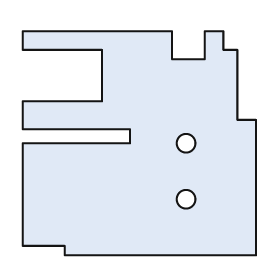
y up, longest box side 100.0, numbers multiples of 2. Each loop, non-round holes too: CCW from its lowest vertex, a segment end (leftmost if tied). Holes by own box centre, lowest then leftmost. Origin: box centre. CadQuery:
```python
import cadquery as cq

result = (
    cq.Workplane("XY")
    .moveTo(-32.0, -48.0)
    .lineTo(50.0, -48.0)
    .lineTo(50.0, 10.0)
    .lineTo(42.0, 10.0)
    .lineTo(42.0, 40.0)
    .lineTo(36.0, 40.0)
    .lineTo(36.0, 48.0)
    .lineTo(28.0, 48.0)
    .lineTo(28.0, 36.0)
    .lineTo(14.0, 36.0)
    .lineTo(14.0, 48.0)
    .lineTo(-50.0, 48.0)
    .lineTo(-50.0, 40.0)
    .lineTo(-16.0, 40.0)
    .lineTo(-16.0, 18.0)
    .lineTo(-50.0, 18.0)
    .lineTo(-50.0, 6.0)
    .lineTo(-4.0, 6.0)
    .lineTo(-4.0, 0.0)
    .lineTo(-50.0, 0.0)
    .lineTo(-50.0, -44.0)
    .lineTo(-32.0, -44.0)
    .close()
    .moveTo(20.0, -24.0)
    .circle(4.0)
    .moveTo(20.0, 0.0)
    .circle(4.0)
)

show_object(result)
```